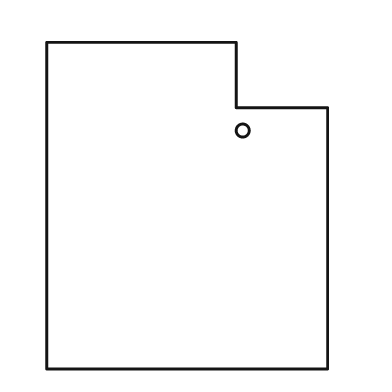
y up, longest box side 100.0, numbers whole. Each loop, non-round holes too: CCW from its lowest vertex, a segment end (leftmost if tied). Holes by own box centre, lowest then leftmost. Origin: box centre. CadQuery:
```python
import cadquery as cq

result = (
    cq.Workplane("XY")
    .moveTo(-43.0, -50.0)
    .lineTo(43.0, -50.0)
    .lineTo(43.0, 30.0)
    .lineTo(15.0, 30.0)
    .lineTo(15.0, 50.0)
    .lineTo(-43.0, 50.0)
    .close()
    .moveTo(17.0, 23.0)
    .circle(2.0)
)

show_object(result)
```